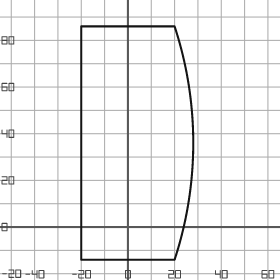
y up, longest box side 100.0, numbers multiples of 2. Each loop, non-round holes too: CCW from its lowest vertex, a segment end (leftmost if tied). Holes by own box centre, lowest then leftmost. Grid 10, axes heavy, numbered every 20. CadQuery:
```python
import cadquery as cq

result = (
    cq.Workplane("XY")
    .moveTo(-20.0, -14.0)
    .lineTo(20.0, -14.0)
    .threePointArc((28.0, 36.0), (20.0, 86.0))
    .lineTo(-20.0, 86.0)
    .close()
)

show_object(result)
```